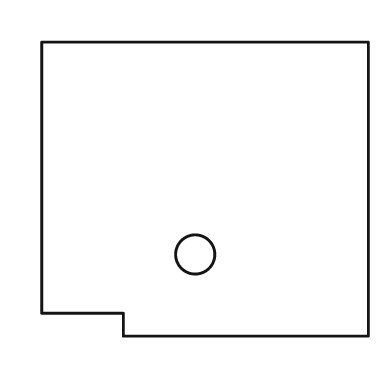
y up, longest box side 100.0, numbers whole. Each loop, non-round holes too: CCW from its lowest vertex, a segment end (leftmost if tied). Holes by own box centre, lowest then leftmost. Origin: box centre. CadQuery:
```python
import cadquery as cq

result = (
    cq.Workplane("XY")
    .moveTo(-25.0, -45.0)
    .lineTo(50.0, -45.0)
    .lineTo(50.0, 45.0)
    .lineTo(-50.0, 45.0)
    .lineTo(-50.0, -38.0)
    .lineTo(-25.0, -38.0)
    .close()
    .moveTo(-3.0, -20.0)
    .circle(6.0)
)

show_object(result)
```